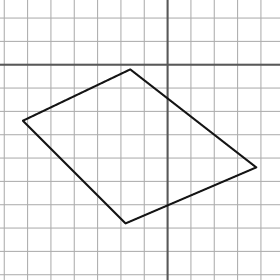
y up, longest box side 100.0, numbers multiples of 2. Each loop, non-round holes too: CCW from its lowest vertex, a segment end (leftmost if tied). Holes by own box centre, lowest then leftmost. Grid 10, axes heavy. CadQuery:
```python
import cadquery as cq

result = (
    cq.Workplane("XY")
    .moveTo(-18.0, -68.0)
    .lineTo(38.0, -44.0)
    .lineTo(-16.0, -2.0)
    .lineTo(-62.0, -24.0)
    .close()
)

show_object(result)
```